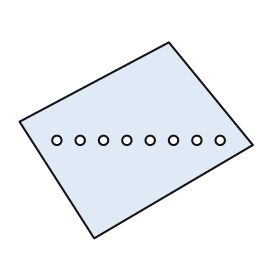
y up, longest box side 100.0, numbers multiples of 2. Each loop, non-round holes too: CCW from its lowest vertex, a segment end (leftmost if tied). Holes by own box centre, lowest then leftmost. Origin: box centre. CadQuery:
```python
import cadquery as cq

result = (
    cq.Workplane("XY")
    .moveTo(-18.0, -42.0)
    .lineTo(50.0, -2.0)
    .lineTo(14.0, 42.0)
    .lineTo(-50.0, 8.0)
    .close()
    .moveTo(-34.0, 0.0)
    .circle(2.0)
    .moveTo(-24.0, 0.0)
    .circle(2.0)
    .moveTo(-14.0, 0.0)
    .circle(2.0)
    .moveTo(-4.0, 0.0)
    .circle(2.0)
    .moveTo(6.0, 0.0)
    .circle(2.0)
    .moveTo(16.0, 0.0)
    .circle(2.0)
    .moveTo(26.0, 0.0)
    .circle(2.0)
    .moveTo(36.0, 0.0)
    .circle(2.0)
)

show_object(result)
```